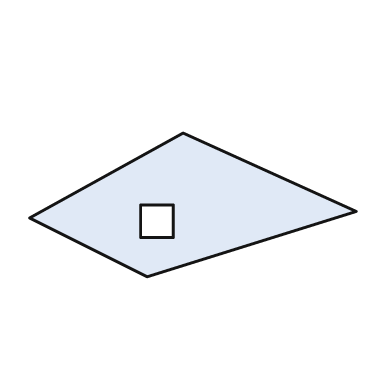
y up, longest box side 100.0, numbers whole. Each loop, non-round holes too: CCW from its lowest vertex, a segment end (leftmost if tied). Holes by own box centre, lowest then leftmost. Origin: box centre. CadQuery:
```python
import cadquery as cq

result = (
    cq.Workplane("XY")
    .moveTo(-14.0, -22.0)
    .lineTo(50.0, -2.0)
    .lineTo(-3.0, 22.0)
    .lineTo(-50.0, -4.0)
    .close()
    .moveTo(-16.0, -10.0)
    .lineTo(-6.0, -10.0)
    .lineTo(-6.0, 0.0)
    .lineTo(-16.0, 0.0)
    .close()
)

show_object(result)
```